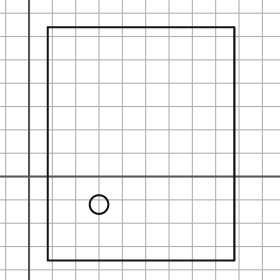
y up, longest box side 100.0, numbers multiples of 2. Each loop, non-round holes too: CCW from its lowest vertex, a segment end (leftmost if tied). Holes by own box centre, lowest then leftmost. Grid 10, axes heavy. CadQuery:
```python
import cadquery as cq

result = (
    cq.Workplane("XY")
    .moveTo(8.0, -36.0)
    .lineTo(88.0, -36.0)
    .lineTo(88.0, 64.0)
    .lineTo(8.0, 64.0)
    .close()
    .moveTo(30.0, -12.0)
    .circle(4.0)
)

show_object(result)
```